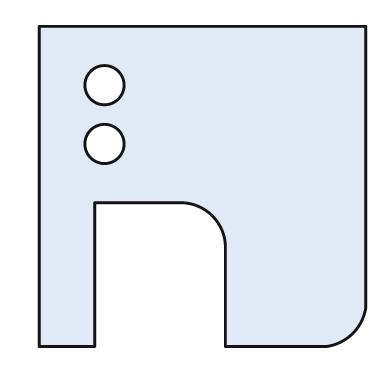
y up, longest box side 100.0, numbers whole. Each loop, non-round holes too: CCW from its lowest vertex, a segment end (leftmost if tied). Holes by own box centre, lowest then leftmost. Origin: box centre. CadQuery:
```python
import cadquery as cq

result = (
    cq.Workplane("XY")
    .moveTo(-50.0, -49.0)
    .lineTo(-33.0, -49.0)
    .lineTo(-33.0, -5.0)
    .lineTo(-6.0, -5.0)
    .threePointArc((3.0, -9.0), (7.0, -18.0))
    .lineTo(7.0, -49.0)
    .lineTo(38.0, -49.0)
    .threePointArc((46.0, -45.0), (50.0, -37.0))
    .lineTo(50.0, 49.0)
    .lineTo(-50.0, 49.0)
    .close()
    .moveTo(-30.0, 13.0)
    .circle(6.0)
    .moveTo(-30.0, 31.0)
    .circle(6.0)
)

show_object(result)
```